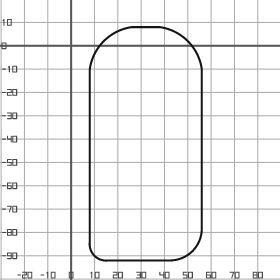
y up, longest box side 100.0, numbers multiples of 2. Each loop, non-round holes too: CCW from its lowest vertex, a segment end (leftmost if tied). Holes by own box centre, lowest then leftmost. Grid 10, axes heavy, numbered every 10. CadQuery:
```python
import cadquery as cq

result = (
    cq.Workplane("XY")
    .moveTo(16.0, -92.0)
    .lineTo(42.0, -92.0)
    .threePointArc((52.0, -88.0), (56.0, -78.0))
    .lineTo(56.0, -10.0)
    .threePointArc((50.0, 2.0), (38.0, 8.0))
    .lineTo(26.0, 8.0)
    .threePointArc((14.0, 2.0), (8.0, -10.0))
    .lineTo(8.0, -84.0)
    .threePointArc((10.0, -90.0), (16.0, -92.0))
    .close()
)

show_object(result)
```